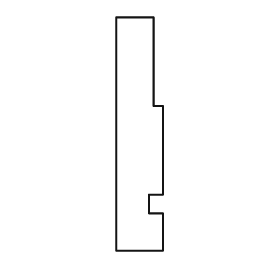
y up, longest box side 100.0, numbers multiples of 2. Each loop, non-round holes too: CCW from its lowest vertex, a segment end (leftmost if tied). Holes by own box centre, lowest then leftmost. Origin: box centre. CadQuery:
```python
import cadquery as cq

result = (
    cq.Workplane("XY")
    .moveTo(-10.0, -50.0)
    .lineTo(10.0, -50.0)
    .lineTo(10.0, -34.0)
    .lineTo(4.0, -34.0)
    .lineTo(4.0, -26.0)
    .lineTo(10.0, -26.0)
    .lineTo(10.0, 12.0)
    .lineTo(6.0, 12.0)
    .lineTo(6.0, 50.0)
    .lineTo(-10.0, 50.0)
    .close()
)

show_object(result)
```